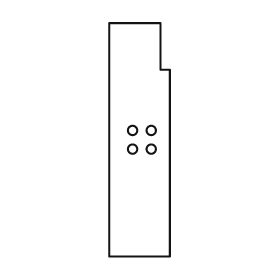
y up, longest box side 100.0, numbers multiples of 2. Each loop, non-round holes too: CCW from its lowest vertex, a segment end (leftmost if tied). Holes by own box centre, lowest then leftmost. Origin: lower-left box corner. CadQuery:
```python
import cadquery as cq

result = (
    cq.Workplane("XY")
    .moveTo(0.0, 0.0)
    .lineTo(26.0, 0.0)
    .lineTo(26.0, 80.0)
    .lineTo(22.0, 80.0)
    .lineTo(22.0, 100.0)
    .lineTo(0.0, 100.0)
    .close()
    .moveTo(10.0, 46.0)
    .circle(2.0)
    .moveTo(18.0, 46.0)
    .circle(2.0)
    .moveTo(10.0, 54.0)
    .circle(2.0)
    .moveTo(18.0, 54.0)
    .circle(2.0)
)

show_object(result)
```